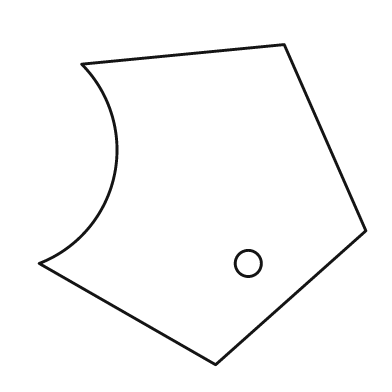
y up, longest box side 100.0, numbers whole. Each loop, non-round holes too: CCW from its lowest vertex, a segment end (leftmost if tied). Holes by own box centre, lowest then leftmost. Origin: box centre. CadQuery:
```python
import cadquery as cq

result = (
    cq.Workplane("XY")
    .moveTo(4.0, -49.0)
    .lineTo(50.0, -8.0)
    .lineTo(25.0, 49.0)
    .lineTo(-37.0, 43.0)
    .threePointArc((-27.0, 9.0), (-50.0, -18.0))
    .close()
    .moveTo(14.0, -18.0)
    .circle(4.0)
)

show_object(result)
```